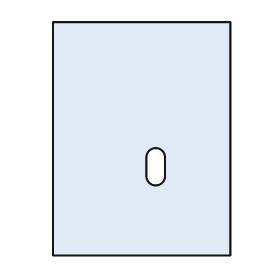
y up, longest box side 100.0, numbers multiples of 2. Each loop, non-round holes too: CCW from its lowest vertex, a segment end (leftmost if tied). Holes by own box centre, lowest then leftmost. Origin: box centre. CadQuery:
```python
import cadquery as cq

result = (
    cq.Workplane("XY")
    .moveTo(-38.0, -50.0)
    .lineTo(38.0, -50.0)
    .lineTo(38.0, 50.0)
    .lineTo(-38.0, 50.0)
    .close()
    .moveTo(2.0, -16.0)
    .threePointArc((6.0, -20.0), (10.0, -16.0))
    .lineTo(10.0, -8.0)
    .threePointArc((6.0, -4.0), (2.0, -8.0))
    .close()
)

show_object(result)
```